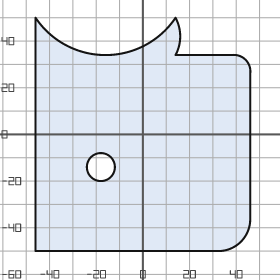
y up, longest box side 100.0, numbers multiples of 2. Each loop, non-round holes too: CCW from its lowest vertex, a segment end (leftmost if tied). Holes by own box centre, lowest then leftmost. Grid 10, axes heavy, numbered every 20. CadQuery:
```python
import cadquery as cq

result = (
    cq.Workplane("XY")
    .moveTo(-46.0, -50.0)
    .lineTo(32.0, -50.0)
    .threePointArc((42.0, -46.0), (46.0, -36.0))
    .lineTo(46.0, 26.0)
    .threePointArc((44.0, 32.0), (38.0, 34.0))
    .lineTo(14.0, 34.0)
    .threePointArc((16.0, 42.0), (14.0, 50.0))
    .threePointArc((-16.0, 34.0), (-46.0, 50.0))
    .close()
    .moveTo(-18.0, -14.0)
    .circle(6.0)
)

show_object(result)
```